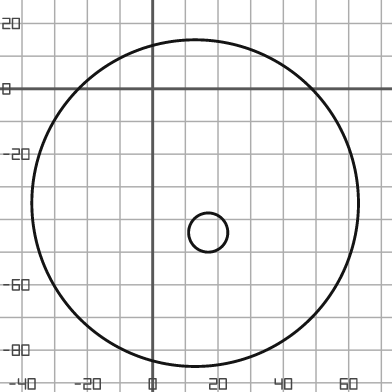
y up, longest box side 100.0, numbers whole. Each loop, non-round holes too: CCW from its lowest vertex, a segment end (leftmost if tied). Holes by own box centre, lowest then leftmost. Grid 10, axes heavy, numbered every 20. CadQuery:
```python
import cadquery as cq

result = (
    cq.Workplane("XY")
    .moveTo(13.0, -35.0)
    .circle(50.0)
    .moveTo(17.0, -44.0)
    .circle(6.0)
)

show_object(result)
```